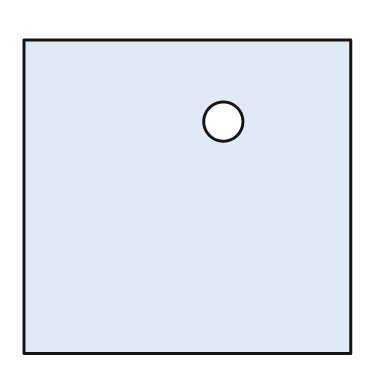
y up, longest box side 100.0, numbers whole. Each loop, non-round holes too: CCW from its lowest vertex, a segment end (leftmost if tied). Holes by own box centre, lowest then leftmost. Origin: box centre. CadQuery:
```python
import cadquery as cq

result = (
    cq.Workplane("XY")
    .moveTo(-50.0, -48.0)
    .lineTo(50.0, -48.0)
    .lineTo(50.0, 48.0)
    .lineTo(-50.0, 48.0)
    .close()
    .moveTo(11.0, 23.0)
    .circle(6.0)
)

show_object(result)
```